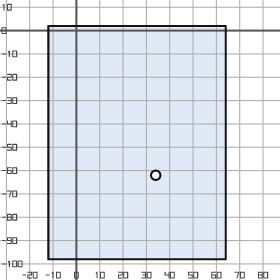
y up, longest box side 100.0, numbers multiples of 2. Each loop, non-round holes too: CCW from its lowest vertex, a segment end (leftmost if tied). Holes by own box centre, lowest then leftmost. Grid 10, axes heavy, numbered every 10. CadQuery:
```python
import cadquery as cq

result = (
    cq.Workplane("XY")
    .moveTo(-12.0, -98.0)
    .lineTo(64.0, -98.0)
    .lineTo(64.0, 2.0)
    .lineTo(-12.0, 2.0)
    .close()
    .moveTo(34.0, -62.0)
    .circle(2.0)
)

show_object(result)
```